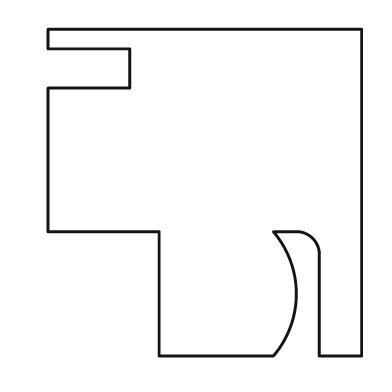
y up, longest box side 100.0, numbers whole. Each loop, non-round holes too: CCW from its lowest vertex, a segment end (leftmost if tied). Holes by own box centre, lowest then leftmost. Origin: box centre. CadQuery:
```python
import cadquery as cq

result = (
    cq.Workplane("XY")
    .moveTo(-14.0, -50.0)
    .lineTo(21.0, -50.0)
    .threePointArc((28.0, -31.0), (21.0, -12.0))
    .lineTo(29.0, -12.0)
    .threePointArc((33.0, -14.0), (35.0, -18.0))
    .lineTo(35.0, -50.0)
    .lineTo(48.0, -50.0)
    .lineTo(48.0, 50.0)
    .lineTo(-48.0, 50.0)
    .lineTo(-48.0, 44.0)
    .lineTo(-23.0, 44.0)
    .lineTo(-23.0, 32.0)
    .lineTo(-48.0, 32.0)
    .lineTo(-48.0, -12.0)
    .lineTo(-14.0, -12.0)
    .close()
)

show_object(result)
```